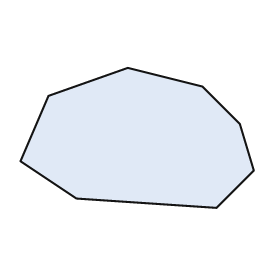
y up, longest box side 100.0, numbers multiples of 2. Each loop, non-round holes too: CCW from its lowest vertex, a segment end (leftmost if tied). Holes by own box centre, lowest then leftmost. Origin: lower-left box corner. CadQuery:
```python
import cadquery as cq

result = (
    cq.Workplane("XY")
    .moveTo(84.0, 0.0)
    .lineTo(100.0, 16.0)
    .lineTo(94.0, 36.0)
    .lineTo(78.0, 52.0)
    .lineTo(46.0, 60.0)
    .lineTo(12.0, 48.0)
    .lineTo(0.0, 20.0)
    .lineTo(24.0, 4.0)
    .close()
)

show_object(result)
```